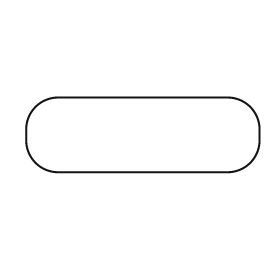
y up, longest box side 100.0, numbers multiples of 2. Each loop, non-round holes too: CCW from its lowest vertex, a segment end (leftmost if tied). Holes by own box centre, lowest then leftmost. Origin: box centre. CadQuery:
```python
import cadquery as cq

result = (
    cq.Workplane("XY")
    .moveTo(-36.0, -16.0)
    .lineTo(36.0, -16.0)
    .threePointArc((46.0, -12.0), (50.0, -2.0))
    .lineTo(50.0, 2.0)
    .threePointArc((46.0, 12.0), (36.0, 16.0))
    .lineTo(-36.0, 16.0)
    .threePointArc((-46.0, 12.0), (-50.0, 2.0))
    .lineTo(-50.0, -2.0)
    .threePointArc((-46.0, -12.0), (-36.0, -16.0))
    .close()
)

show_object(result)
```